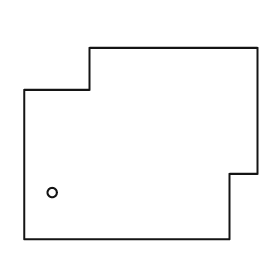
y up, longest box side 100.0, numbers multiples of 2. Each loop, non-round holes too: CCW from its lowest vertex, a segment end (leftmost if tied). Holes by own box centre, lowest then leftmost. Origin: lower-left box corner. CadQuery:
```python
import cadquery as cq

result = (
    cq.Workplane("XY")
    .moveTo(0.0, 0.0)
    .lineTo(88.0, 0.0)
    .lineTo(88.0, 28.0)
    .lineTo(100.0, 28.0)
    .lineTo(100.0, 82.0)
    .lineTo(28.0, 82.0)
    .lineTo(28.0, 64.0)
    .lineTo(0.0, 64.0)
    .close()
    .moveTo(12.0, 20.0)
    .circle(2.0)
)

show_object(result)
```